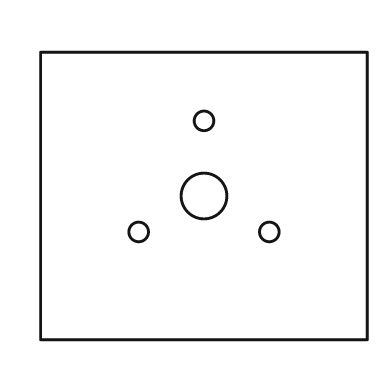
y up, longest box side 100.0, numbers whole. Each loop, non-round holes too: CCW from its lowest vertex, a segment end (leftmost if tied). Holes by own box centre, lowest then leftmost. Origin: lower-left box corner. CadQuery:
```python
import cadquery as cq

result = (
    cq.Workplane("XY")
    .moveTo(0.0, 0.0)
    .lineTo(100.0, 0.0)
    .lineTo(100.0, 88.0)
    .lineTo(0.0, 88.0)
    .close()
    .moveTo(30.0, 33.0)
    .circle(3.0)
    .moveTo(70.0, 33.0)
    .circle(3.0)
    .moveTo(50.0, 44.0)
    .circle(7.0)
    .moveTo(50.0, 67.0)
    .circle(3.0)
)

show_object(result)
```